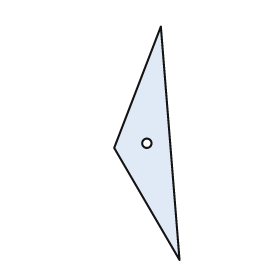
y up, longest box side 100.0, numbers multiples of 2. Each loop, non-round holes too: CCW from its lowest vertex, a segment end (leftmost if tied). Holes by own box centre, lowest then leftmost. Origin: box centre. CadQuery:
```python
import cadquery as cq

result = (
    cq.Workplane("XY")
    .moveTo(14.0, -50.0)
    .lineTo(6.0, 50.0)
    .lineTo(-14.0, -2.0)
    .close()
    .moveTo(0.0, 0.0)
    .circle(2.0)
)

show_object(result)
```